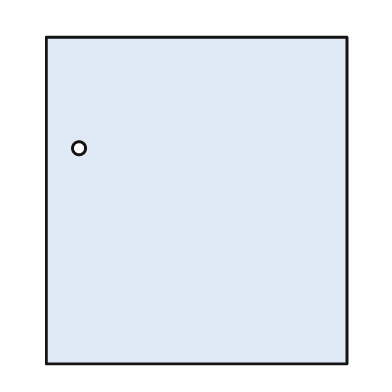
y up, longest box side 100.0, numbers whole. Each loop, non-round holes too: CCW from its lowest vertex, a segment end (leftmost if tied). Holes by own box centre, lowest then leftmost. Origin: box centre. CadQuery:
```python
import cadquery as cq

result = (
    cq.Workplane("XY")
    .moveTo(-46.0, -50.0)
    .lineTo(46.0, -50.0)
    .lineTo(46.0, 50.0)
    .lineTo(-46.0, 50.0)
    .close()
    .moveTo(-36.0, 16.0)
    .circle(2.0)
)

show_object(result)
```